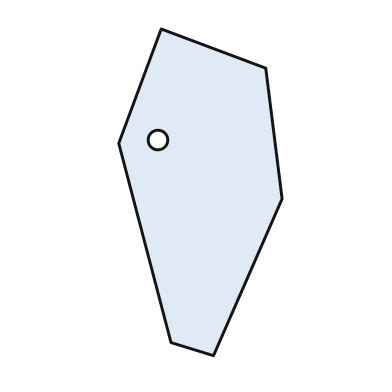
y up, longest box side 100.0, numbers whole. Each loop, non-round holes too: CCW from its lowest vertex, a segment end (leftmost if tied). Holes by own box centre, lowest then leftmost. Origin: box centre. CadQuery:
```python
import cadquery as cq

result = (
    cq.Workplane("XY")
    .moveTo(4.0, -50.0)
    .lineTo(25.0, -2.0)
    .lineTo(20.0, 38.0)
    .lineTo(-12.0, 50.0)
    .lineTo(-25.0, 15.0)
    .lineTo(-9.0, -46.0)
    .close()
    .moveTo(-13.0, 16.0)
    .circle(3.0)
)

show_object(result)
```